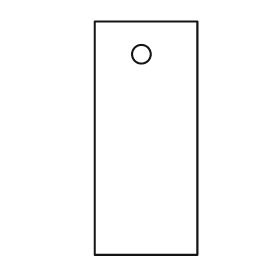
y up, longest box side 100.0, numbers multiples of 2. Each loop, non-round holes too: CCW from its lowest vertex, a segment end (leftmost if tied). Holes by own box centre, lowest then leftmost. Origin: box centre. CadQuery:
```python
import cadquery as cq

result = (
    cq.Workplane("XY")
    .moveTo(-22.0, -50.0)
    .lineTo(22.0, -50.0)
    .lineTo(22.0, 50.0)
    .lineTo(-22.0, 50.0)
    .close()
    .moveTo(-2.0, 36.0)
    .circle(4.0)
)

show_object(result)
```